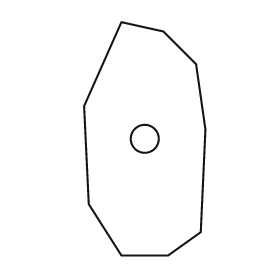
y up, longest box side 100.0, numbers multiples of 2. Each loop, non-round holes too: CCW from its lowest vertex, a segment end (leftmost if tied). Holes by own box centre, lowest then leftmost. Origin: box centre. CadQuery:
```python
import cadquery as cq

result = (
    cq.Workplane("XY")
    .moveTo(-10.0, -50.0)
    .lineTo(10.0, -50.0)
    .lineTo(24.0, -40.0)
    .lineTo(26.0, 4.0)
    .lineTo(22.0, 32.0)
    .lineTo(8.0, 46.0)
    .lineTo(-10.0, 50.0)
    .lineTo(-26.0, 14.0)
    .lineTo(-24.0, -28.0)
    .close()
    .moveTo(0.0, 0.0)
    .circle(6.0)
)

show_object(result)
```